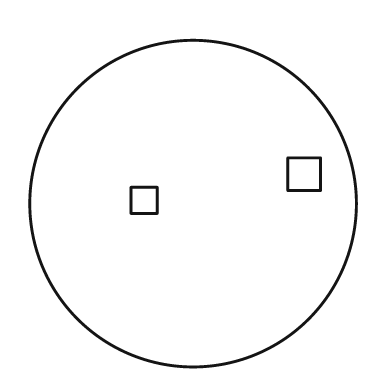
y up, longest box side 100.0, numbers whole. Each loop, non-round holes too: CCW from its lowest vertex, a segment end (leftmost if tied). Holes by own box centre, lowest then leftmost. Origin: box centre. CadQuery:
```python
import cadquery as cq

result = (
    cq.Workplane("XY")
    .moveTo(0.0, 0.0)
    .circle(50.0)
    .moveTo(-19.0, -3.0)
    .lineTo(-11.0, -3.0)
    .lineTo(-11.0, 5.0)
    .lineTo(-19.0, 5.0)
    .close()
    .moveTo(29.0, 4.0)
    .lineTo(39.0, 4.0)
    .lineTo(39.0, 14.0)
    .lineTo(29.0, 14.0)
    .close()
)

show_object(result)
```